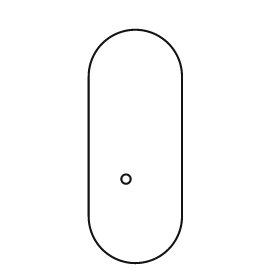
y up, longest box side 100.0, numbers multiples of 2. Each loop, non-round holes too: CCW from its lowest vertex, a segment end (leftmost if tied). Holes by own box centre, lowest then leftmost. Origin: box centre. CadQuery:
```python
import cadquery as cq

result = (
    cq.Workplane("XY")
    .moveTo(-20.0, -30.0)
    .threePointArc((0.0, -50.0), (20.0, -30.0))
    .lineTo(20.0, 30.0)
    .threePointArc((0.0, 50.0), (-20.0, 30.0))
    .close()
    .moveTo(-4.0, -14.0)
    .circle(2.0)
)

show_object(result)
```